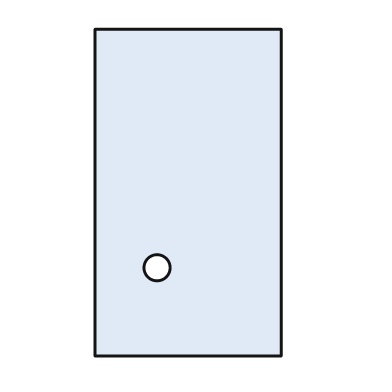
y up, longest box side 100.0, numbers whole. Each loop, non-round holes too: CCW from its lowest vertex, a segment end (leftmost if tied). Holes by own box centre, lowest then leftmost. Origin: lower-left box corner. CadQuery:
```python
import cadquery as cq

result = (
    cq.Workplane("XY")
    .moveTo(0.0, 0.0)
    .lineTo(57.0, 0.0)
    .lineTo(57.0, 100.0)
    .lineTo(0.0, 100.0)
    .close()
    .moveTo(19.0, 27.0)
    .circle(4.0)
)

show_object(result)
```